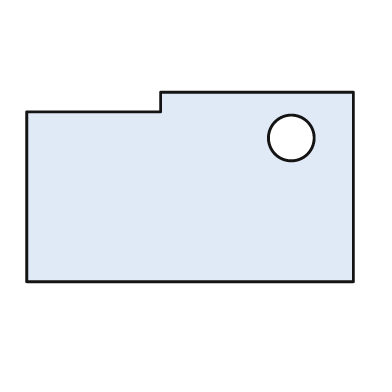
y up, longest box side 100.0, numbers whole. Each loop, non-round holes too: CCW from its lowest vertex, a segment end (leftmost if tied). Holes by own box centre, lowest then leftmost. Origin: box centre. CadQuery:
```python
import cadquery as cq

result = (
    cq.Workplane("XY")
    .moveTo(-50.0, -29.0)
    .lineTo(50.0, -29.0)
    .lineTo(50.0, 29.0)
    .lineTo(-9.0, 29.0)
    .lineTo(-9.0, 23.0)
    .lineTo(-50.0, 23.0)
    .close()
    .moveTo(31.0, 15.0)
    .circle(7.0)
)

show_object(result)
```